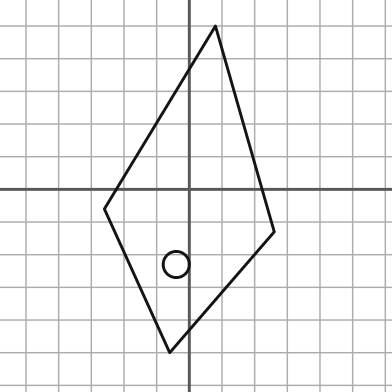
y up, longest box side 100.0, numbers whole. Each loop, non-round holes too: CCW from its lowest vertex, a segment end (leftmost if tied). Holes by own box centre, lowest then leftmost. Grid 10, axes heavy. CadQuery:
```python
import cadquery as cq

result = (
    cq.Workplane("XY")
    .moveTo(-6.0, -50.0)
    .lineTo(26.0, -13.0)
    .lineTo(8.0, 50.0)
    .lineTo(-26.0, -6.0)
    .close()
    .moveTo(-4.0, -23.0)
    .circle(4.0)
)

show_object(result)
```